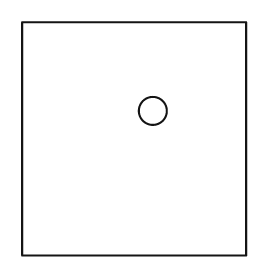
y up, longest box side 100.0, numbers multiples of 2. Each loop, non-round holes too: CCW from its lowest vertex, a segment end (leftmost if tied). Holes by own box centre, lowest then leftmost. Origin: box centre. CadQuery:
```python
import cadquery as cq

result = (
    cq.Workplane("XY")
    .moveTo(-48.0, -50.0)
    .lineTo(48.0, -50.0)
    .lineTo(48.0, 50.0)
    .lineTo(-48.0, 50.0)
    .close()
    .moveTo(8.0, 12.0)
    .circle(6.0)
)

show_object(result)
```